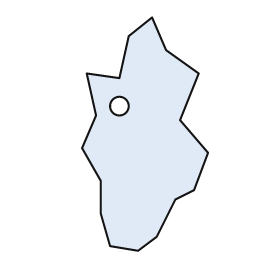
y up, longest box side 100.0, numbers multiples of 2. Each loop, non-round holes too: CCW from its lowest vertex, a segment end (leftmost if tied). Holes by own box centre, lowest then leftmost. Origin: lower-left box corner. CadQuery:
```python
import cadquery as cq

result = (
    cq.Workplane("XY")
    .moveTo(24.0, 0.0)
    .lineTo(32.0, 6.0)
    .lineTo(40.0, 22.0)
    .lineTo(48.0, 26.0)
    .lineTo(54.0, 42.0)
    .lineTo(42.0, 56.0)
    .lineTo(50.0, 76.0)
    .lineTo(36.0, 86.0)
    .lineTo(30.0, 100.0)
    .lineTo(20.0, 92.0)
    .lineTo(16.0, 74.0)
    .lineTo(2.0, 76.0)
    .lineTo(6.0, 58.0)
    .lineTo(0.0, 44.0)
    .lineTo(8.0, 30.0)
    .lineTo(8.0, 16.0)
    .lineTo(12.0, 2.0)
    .close()
    .moveTo(16.0, 62.0)
    .circle(4.0)
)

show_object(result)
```